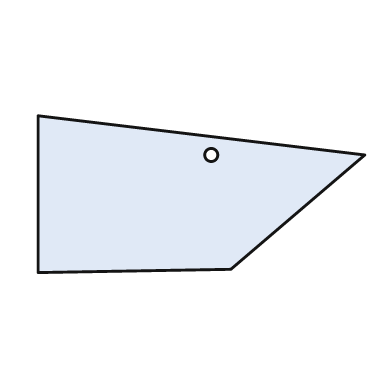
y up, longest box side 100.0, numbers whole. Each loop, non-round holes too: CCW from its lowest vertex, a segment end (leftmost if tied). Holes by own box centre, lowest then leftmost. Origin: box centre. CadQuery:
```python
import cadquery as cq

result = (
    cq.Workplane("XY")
    .moveTo(-50.0, -24.0)
    .lineTo(9.0, -23.0)
    .lineTo(50.0, 12.0)
    .lineTo(-50.0, 24.0)
    .close()
    .moveTo(3.0, 12.0)
    .circle(2.0)
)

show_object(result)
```